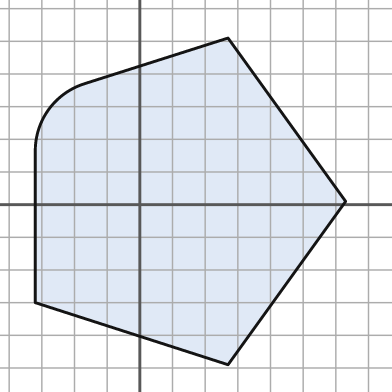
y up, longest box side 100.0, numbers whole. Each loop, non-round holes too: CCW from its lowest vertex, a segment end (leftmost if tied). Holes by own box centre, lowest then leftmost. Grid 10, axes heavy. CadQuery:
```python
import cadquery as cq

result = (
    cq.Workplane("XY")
    .moveTo(27.0, -49.0)
    .lineTo(63.0, 1.0)
    .lineTo(27.0, 51.0)
    .lineTo(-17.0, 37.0)
    .threePointArc((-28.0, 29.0), (-32.0, 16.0))
    .lineTo(-32.0, -30.0)
    .close()
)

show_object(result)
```